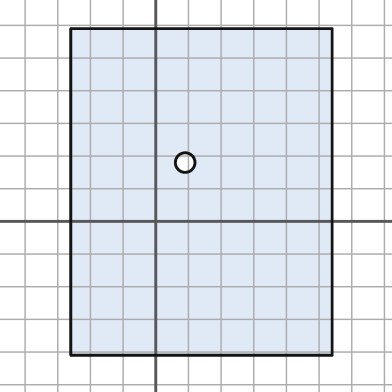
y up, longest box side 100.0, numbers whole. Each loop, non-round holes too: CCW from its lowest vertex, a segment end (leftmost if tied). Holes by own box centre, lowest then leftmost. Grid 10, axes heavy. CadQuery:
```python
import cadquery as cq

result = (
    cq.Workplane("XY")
    .moveTo(-26.0, -41.0)
    .lineTo(54.0, -41.0)
    .lineTo(54.0, 59.0)
    .lineTo(-26.0, 59.0)
    .close()
    .moveTo(9.0, 18.0)
    .circle(3.0)
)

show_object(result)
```